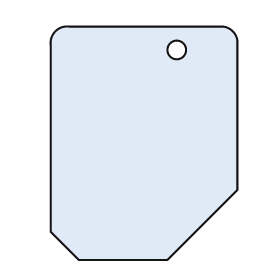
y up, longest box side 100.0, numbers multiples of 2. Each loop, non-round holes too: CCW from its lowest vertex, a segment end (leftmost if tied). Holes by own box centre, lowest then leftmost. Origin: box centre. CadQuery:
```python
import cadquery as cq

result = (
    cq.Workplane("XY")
    .moveTo(-28.0, -50.0)
    .lineTo(10.0, -50.0)
    .lineTo(40.0, -20.0)
    .lineTo(40.0, 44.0)
    .threePointArc((38.0, 48.0), (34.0, 50.0))
    .lineTo(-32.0, 50.0)
    .threePointArc((-38.0, 48.0), (-40.0, 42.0))
    .lineTo(-40.0, -38.0)
    .close()
    .moveTo(14.0, 40.0)
    .circle(4.0)
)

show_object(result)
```